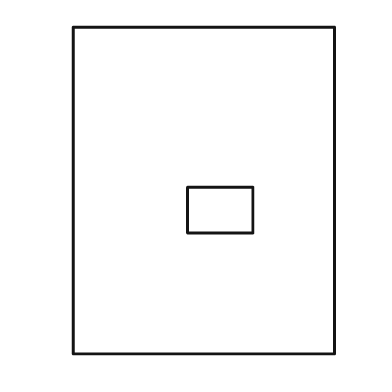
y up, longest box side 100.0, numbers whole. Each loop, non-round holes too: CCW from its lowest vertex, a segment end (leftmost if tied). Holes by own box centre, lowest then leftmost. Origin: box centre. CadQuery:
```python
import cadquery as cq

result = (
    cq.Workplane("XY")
    .moveTo(-40.0, -50.0)
    .lineTo(40.0, -50.0)
    .lineTo(40.0, 50.0)
    .lineTo(-40.0, 50.0)
    .close()
    .moveTo(-5.0, -13.0)
    .lineTo(15.0, -13.0)
    .lineTo(15.0, 1.0)
    .lineTo(-5.0, 1.0)
    .close()
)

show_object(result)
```